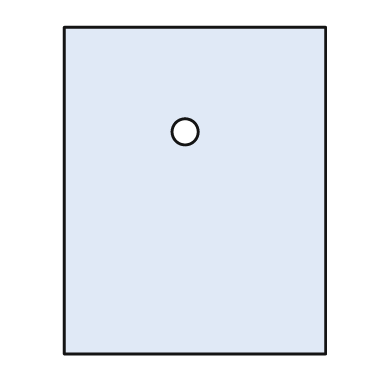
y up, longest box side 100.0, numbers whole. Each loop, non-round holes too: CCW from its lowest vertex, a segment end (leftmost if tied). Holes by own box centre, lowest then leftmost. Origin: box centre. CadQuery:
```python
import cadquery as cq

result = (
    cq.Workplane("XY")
    .moveTo(-40.0, -50.0)
    .lineTo(40.0, -50.0)
    .lineTo(40.0, 50.0)
    .lineTo(-40.0, 50.0)
    .close()
    .moveTo(-3.0, 18.0)
    .circle(4.0)
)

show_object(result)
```